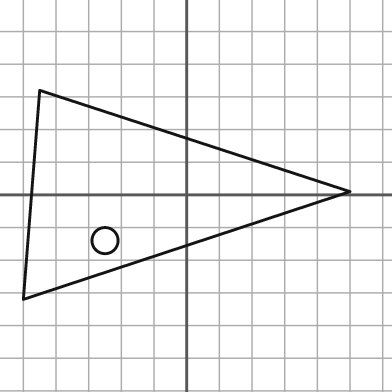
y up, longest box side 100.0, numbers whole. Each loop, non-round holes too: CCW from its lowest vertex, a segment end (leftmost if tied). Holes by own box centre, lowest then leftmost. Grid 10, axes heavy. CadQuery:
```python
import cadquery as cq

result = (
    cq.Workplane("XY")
    .moveTo(-50.0, -32.0)
    .lineTo(50.0, 1.0)
    .lineTo(-45.0, 32.0)
    .close()
    .moveTo(-25.0, -14.0)
    .circle(4.0)
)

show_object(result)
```